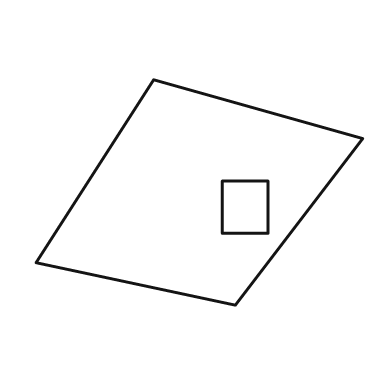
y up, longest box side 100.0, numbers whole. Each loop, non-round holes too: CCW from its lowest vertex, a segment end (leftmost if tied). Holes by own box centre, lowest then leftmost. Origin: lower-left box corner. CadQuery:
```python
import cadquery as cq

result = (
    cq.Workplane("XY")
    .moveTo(61.0, 0.0)
    .lineTo(100.0, 51.0)
    .lineTo(36.0, 69.0)
    .lineTo(0.0, 13.0)
    .close()
    .moveTo(57.0, 22.0)
    .lineTo(71.0, 22.0)
    .lineTo(71.0, 38.0)
    .lineTo(57.0, 38.0)
    .close()
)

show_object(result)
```